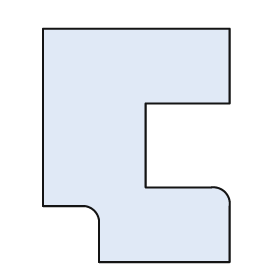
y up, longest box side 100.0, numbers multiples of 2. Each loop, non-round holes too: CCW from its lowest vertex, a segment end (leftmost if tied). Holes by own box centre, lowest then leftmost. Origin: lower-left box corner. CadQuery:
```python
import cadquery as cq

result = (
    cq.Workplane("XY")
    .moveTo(24.0, 0.0)
    .lineTo(80.0, 0.0)
    .lineTo(80.0, 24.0)
    .threePointArc((78.0, 30.0), (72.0, 32.0))
    .lineTo(44.0, 32.0)
    .lineTo(44.0, 68.0)
    .lineTo(80.0, 68.0)
    .lineTo(80.0, 100.0)
    .lineTo(0.0, 100.0)
    .lineTo(0.0, 24.0)
    .lineTo(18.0, 24.0)
    .threePointArc((22.0, 22.0), (24.0, 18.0))
    .close()
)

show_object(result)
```